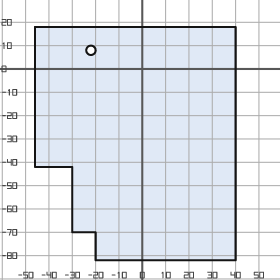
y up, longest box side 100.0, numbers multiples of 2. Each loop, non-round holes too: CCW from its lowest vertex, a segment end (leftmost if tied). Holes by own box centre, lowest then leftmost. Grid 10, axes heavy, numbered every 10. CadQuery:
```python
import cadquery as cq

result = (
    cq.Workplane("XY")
    .moveTo(-20.0, -82.0)
    .lineTo(40.0, -82.0)
    .lineTo(40.0, 18.0)
    .lineTo(-46.0, 18.0)
    .lineTo(-46.0, -42.0)
    .lineTo(-30.0, -42.0)
    .lineTo(-30.0, -70.0)
    .lineTo(-20.0, -70.0)
    .close()
    .moveTo(-22.0, 8.0)
    .circle(2.0)
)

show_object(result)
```